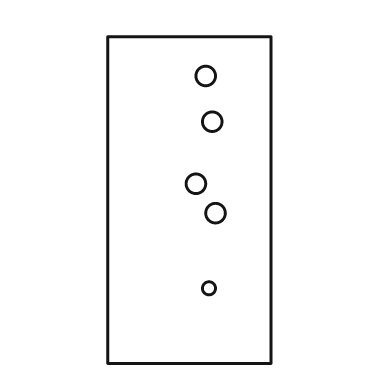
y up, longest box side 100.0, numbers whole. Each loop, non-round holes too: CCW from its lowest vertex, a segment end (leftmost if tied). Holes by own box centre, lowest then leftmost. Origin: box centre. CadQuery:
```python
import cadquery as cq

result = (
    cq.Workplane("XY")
    .moveTo(-25.0, -50.0)
    .lineTo(25.0, -50.0)
    .lineTo(25.0, 50.0)
    .lineTo(-25.0, 50.0)
    .close()
    .moveTo(6.0, -27.0)
    .circle(2.0)
    .moveTo(8.0, -4.0)
    .circle(3.0)
    .moveTo(2.0, 5.0)
    .circle(3.0)
    .moveTo(7.0, 24.0)
    .circle(3.0)
    .moveTo(5.0, 38.0)
    .circle(3.0)
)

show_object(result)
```